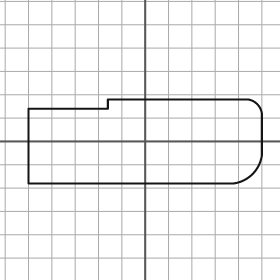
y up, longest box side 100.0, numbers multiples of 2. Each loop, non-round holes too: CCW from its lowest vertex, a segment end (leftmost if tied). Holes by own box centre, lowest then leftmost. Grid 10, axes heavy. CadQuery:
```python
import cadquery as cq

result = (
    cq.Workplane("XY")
    .moveTo(-50.0, -18.0)
    .lineTo(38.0, -18.0)
    .threePointArc((46.0, -14.0), (50.0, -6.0))
    .lineTo(50.0, 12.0)
    .threePointArc((48.0, 16.0), (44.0, 18.0))
    .lineTo(-16.0, 18.0)
    .lineTo(-16.0, 14.0)
    .lineTo(-50.0, 14.0)
    .close()
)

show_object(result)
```